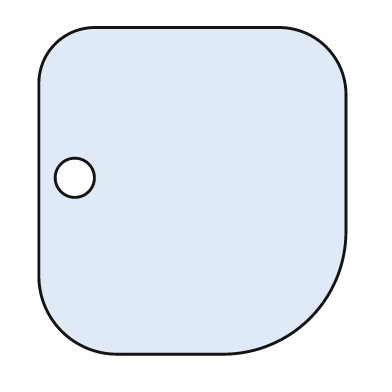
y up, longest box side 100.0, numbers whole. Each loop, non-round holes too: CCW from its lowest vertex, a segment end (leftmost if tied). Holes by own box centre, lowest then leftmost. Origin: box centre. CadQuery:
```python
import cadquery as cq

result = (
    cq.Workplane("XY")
    .moveTo(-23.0, -50.0)
    .lineTo(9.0, -50.0)
    .threePointArc((36.0, -39.0), (47.0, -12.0))
    .lineTo(47.0, 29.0)
    .threePointArc((41.0, 44.0), (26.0, 50.0))
    .lineTo(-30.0, 50.0)
    .threePointArc((-42.0, 45.0), (-47.0, 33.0))
    .lineTo(-47.0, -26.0)
    .threePointArc((-40.0, -43.0), (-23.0, -50.0))
    .close()
    .moveTo(-36.0, 4.0)
    .circle(6.0)
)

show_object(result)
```